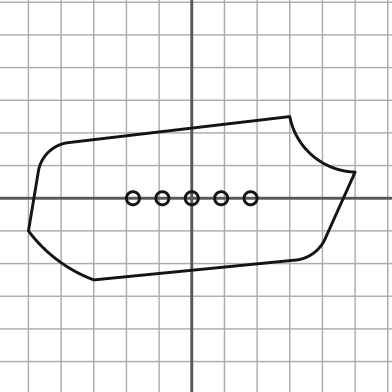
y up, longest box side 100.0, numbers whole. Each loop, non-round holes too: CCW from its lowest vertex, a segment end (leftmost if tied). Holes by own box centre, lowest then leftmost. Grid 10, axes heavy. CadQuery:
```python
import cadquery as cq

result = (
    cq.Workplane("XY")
    .moveTo(-30.0, -25.0)
    .lineTo(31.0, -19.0)
    .threePointArc((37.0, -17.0), (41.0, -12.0))
    .lineTo(50.0, 8.0)
    .threePointArc((37.0, 13.0), (30.0, 25.0))
    .lineTo(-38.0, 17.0)
    .threePointArc((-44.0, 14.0), (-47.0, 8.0))
    .lineTo(-50.0, -10.0)
    .threePointArc((-41.0, -19.0), (-30.0, -25.0))
    .close()
    .moveTo(-18.0, 0.0)
    .circle(2.0)
    .moveTo(-9.0, 0.0)
    .circle(2.0)
    .moveTo(0.0, 0.0)
    .circle(2.0)
    .moveTo(9.0, 0.0)
    .circle(2.0)
    .moveTo(18.0, 0.0)
    .circle(2.0)
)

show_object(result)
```